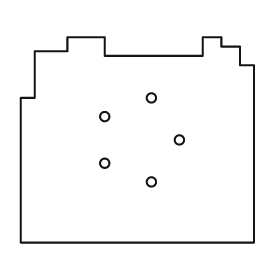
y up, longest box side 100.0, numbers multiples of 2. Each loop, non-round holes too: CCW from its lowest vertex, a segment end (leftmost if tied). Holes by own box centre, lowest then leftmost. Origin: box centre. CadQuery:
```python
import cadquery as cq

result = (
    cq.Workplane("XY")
    .moveTo(-50.0, -44.0)
    .lineTo(50.0, -44.0)
    .lineTo(50.0, 32.0)
    .lineTo(44.0, 32.0)
    .lineTo(44.0, 40.0)
    .lineTo(36.0, 40.0)
    .lineTo(36.0, 44.0)
    .lineTo(28.0, 44.0)
    .lineTo(28.0, 36.0)
    .lineTo(-14.0, 36.0)
    .lineTo(-14.0, 44.0)
    .lineTo(-30.0, 44.0)
    .lineTo(-30.0, 38.0)
    .lineTo(-44.0, 38.0)
    .lineTo(-44.0, 18.0)
    .lineTo(-50.0, 18.0)
    .close()
    .moveTo(6.0, -18.0)
    .circle(2.0)
    .moveTo(-14.0, -10.0)
    .circle(2.0)
    .moveTo(18.0, 0.0)
    .circle(2.0)
    .moveTo(-14.0, 10.0)
    .circle(2.0)
    .moveTo(6.0, 18.0)
    .circle(2.0)
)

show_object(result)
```